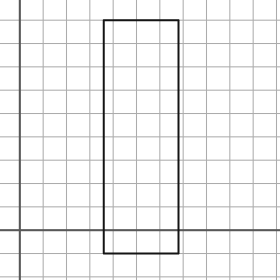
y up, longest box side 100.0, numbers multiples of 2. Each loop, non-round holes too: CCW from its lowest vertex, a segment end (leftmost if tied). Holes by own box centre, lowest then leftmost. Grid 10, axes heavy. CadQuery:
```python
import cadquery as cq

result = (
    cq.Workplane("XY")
    .moveTo(36.0, -10.0)
    .lineTo(68.0, -10.0)
    .lineTo(68.0, 90.0)
    .lineTo(36.0, 90.0)
    .close()
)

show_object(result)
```